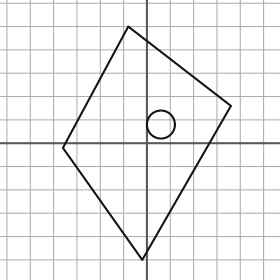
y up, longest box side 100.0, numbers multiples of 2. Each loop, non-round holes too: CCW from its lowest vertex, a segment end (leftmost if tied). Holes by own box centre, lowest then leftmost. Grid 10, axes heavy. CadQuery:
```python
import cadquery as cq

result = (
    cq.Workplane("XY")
    .moveTo(-2.0, -50.0)
    .lineTo(36.0, 16.0)
    .lineTo(-8.0, 50.0)
    .lineTo(-36.0, -2.0)
    .close()
    .moveTo(6.0, 8.0)
    .circle(6.0)
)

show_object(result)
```